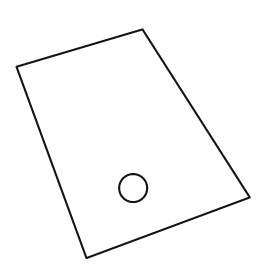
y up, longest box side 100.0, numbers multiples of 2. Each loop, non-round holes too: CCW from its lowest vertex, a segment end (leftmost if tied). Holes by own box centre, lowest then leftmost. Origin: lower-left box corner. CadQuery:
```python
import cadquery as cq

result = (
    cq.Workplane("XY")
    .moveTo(30.0, 0.0)
    .lineTo(100.0, 26.0)
    .lineTo(54.0, 98.0)
    .lineTo(0.0, 82.0)
    .close()
    .moveTo(50.0, 30.0)
    .circle(6.0)
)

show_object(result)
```